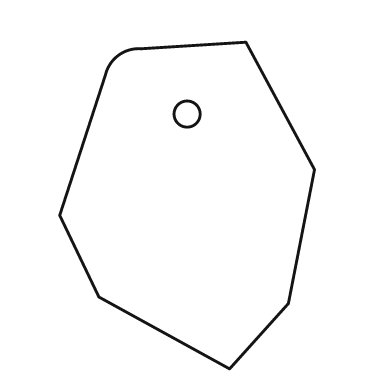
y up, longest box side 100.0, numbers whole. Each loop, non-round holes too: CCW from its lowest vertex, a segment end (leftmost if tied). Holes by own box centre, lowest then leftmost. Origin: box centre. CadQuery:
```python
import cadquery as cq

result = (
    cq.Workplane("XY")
    .moveTo(13.0, -50.0)
    .lineTo(31.0, -30.0)
    .lineTo(39.0, 11.0)
    .lineTo(18.0, 50.0)
    .lineTo(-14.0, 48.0)
    .threePointArc((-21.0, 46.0), (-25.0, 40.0))
    .lineTo(-39.0, -3.0)
    .lineTo(-27.0, -28.0)
    .close()
    .moveTo(0.0, 28.0)
    .circle(4.0)
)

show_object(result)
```